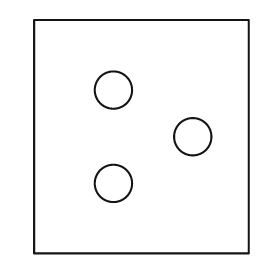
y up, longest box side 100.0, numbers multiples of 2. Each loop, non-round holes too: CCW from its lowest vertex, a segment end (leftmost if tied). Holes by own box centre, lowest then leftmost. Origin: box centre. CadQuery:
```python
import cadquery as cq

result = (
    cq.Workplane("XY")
    .moveTo(-46.0, -50.0)
    .lineTo(46.0, -50.0)
    .lineTo(46.0, 50.0)
    .lineTo(-46.0, 50.0)
    .close()
    .moveTo(-12.0, -20.0)
    .circle(8.0)
    .moveTo(22.0, 0.0)
    .circle(8.0)
    .moveTo(-12.0, 20.0)
    .circle(8.0)
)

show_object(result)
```